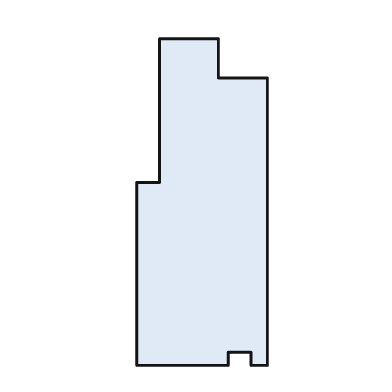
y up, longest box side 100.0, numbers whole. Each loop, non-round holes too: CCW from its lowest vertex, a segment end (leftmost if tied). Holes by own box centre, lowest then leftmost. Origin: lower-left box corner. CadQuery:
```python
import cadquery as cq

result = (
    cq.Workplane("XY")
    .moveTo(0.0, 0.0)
    .lineTo(28.0, 0.0)
    .lineTo(28.0, 4.0)
    .lineTo(35.0, 4.0)
    .lineTo(35.0, 0.0)
    .lineTo(40.0, 0.0)
    .lineTo(40.0, 88.0)
    .lineTo(25.0, 88.0)
    .lineTo(25.0, 100.0)
    .lineTo(7.0, 100.0)
    .lineTo(7.0, 56.0)
    .lineTo(0.0, 56.0)
    .close()
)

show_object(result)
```